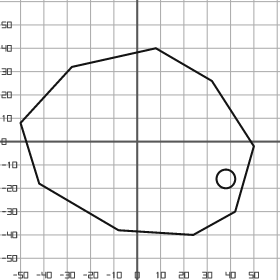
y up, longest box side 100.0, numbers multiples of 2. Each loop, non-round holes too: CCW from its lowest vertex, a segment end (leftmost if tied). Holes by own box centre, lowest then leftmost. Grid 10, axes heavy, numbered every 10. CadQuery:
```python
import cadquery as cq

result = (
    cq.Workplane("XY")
    .moveTo(24.0, -40.0)
    .lineTo(42.0, -30.0)
    .lineTo(50.0, -2.0)
    .lineTo(32.0, 26.0)
    .lineTo(8.0, 40.0)
    .lineTo(-28.0, 32.0)
    .lineTo(-50.0, 8.0)
    .lineTo(-42.0, -18.0)
    .lineTo(-8.0, -38.0)
    .close()
    .moveTo(38.0, -16.0)
    .circle(4.0)
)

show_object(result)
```